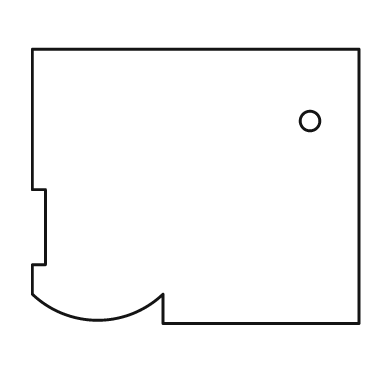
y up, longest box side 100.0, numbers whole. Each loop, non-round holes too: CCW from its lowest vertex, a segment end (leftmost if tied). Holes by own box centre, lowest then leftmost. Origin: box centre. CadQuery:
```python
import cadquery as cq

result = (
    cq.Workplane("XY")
    .moveTo(-10.0, -42.0)
    .lineTo(50.0, -42.0)
    .lineTo(50.0, 42.0)
    .lineTo(-50.0, 42.0)
    .lineTo(-50.0, -1.0)
    .lineTo(-46.0, -1.0)
    .lineTo(-46.0, -24.0)
    .lineTo(-50.0, -24.0)
    .lineTo(-50.0, -33.0)
    .threePointArc((-30.0, -41.0), (-10.0, -33.0))
    .close()
    .moveTo(35.0, 20.0)
    .circle(3.0)
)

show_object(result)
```